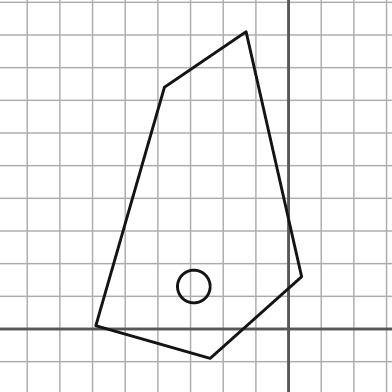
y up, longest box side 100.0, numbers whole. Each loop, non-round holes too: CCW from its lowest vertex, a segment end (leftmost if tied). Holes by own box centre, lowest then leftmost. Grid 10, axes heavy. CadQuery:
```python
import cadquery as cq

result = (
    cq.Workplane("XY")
    .moveTo(-24.0, -9.0)
    .lineTo(4.0, 16.0)
    .lineTo(-13.0, 91.0)
    .lineTo(-38.0, 74.0)
    .lineTo(-59.0, 1.0)
    .close()
    .moveTo(-29.0, 13.0)
    .circle(5.0)
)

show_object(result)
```